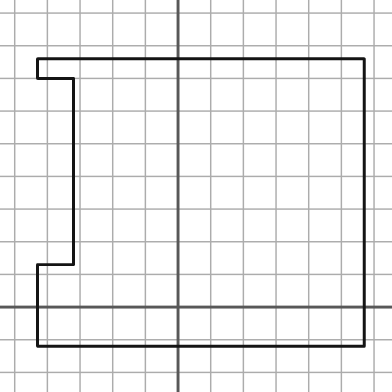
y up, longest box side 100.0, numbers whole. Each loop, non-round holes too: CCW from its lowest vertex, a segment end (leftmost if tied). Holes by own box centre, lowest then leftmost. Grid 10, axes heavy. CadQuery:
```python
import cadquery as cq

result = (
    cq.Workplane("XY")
    .moveTo(-43.0, -12.0)
    .lineTo(57.0, -12.0)
    .lineTo(57.0, 76.0)
    .lineTo(-43.0, 76.0)
    .lineTo(-43.0, 70.0)
    .lineTo(-32.0, 70.0)
    .lineTo(-32.0, 13.0)
    .lineTo(-43.0, 13.0)
    .close()
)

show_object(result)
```